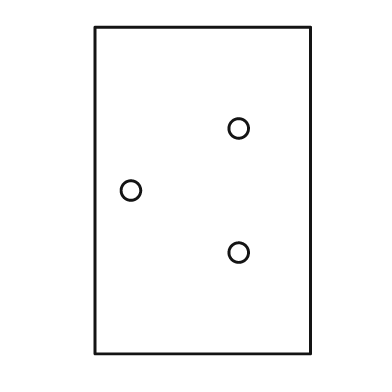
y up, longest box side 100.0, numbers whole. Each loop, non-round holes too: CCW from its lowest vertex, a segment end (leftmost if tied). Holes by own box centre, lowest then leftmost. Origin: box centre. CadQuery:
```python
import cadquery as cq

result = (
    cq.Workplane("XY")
    .moveTo(-33.0, -50.0)
    .lineTo(33.0, -50.0)
    .lineTo(33.0, 50.0)
    .lineTo(-33.0, 50.0)
    .close()
    .moveTo(11.0, -19.0)
    .circle(3.0)
    .moveTo(-22.0, 0.0)
    .circle(3.0)
    .moveTo(11.0, 19.0)
    .circle(3.0)
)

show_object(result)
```